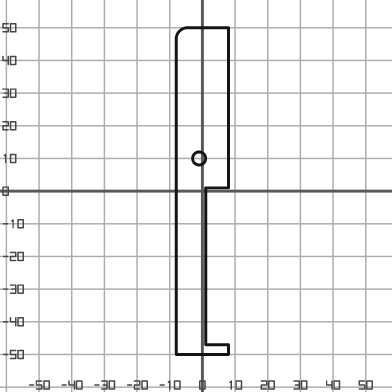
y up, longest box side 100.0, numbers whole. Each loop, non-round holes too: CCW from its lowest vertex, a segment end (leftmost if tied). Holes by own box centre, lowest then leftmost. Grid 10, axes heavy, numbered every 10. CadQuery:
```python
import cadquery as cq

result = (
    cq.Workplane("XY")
    .moveTo(-8.0, -50.0)
    .lineTo(8.0, -50.0)
    .lineTo(8.0, -47.0)
    .lineTo(1.0, -47.0)
    .lineTo(1.0, 1.0)
    .lineTo(8.0, 1.0)
    .lineTo(8.0, 50.0)
    .lineTo(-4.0, 50.0)
    .threePointArc((-7.0, 49.0), (-8.0, 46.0))
    .close()
    .moveTo(-1.0, 10.0)
    .circle(2.0)
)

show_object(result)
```